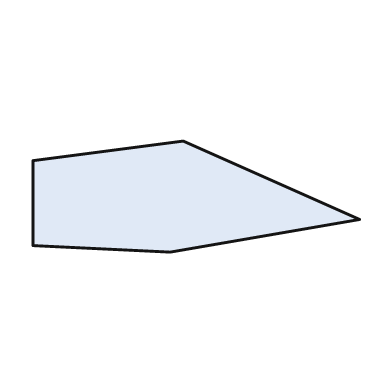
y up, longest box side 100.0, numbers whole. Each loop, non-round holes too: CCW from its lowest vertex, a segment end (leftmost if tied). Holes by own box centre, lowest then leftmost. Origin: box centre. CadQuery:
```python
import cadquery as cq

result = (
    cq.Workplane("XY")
    .moveTo(-8.0, -17.0)
    .lineTo(50.0, -7.0)
    .lineTo(-4.0, 17.0)
    .lineTo(-50.0, 11.0)
    .lineTo(-50.0, -15.0)
    .close()
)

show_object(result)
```